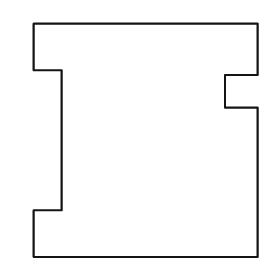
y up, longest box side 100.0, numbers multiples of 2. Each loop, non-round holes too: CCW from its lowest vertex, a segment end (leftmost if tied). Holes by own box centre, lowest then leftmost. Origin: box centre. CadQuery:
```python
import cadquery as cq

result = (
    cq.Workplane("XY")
    .moveTo(-48.0, -50.0)
    .lineTo(48.0, -50.0)
    .lineTo(48.0, 14.0)
    .lineTo(34.0, 14.0)
    .lineTo(34.0, 28.0)
    .lineTo(48.0, 28.0)
    .lineTo(48.0, 50.0)
    .lineTo(-48.0, 50.0)
    .lineTo(-48.0, 30.0)
    .lineTo(-36.0, 30.0)
    .lineTo(-36.0, -30.0)
    .lineTo(-48.0, -30.0)
    .close()
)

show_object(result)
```